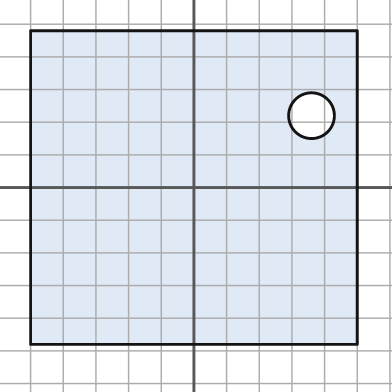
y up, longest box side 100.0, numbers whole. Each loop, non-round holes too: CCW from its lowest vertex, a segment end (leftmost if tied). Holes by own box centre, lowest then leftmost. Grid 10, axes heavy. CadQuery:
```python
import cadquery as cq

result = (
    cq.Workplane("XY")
    .moveTo(-50.0, -48.0)
    .lineTo(50.0, -48.0)
    .lineTo(50.0, 48.0)
    .lineTo(-50.0, 48.0)
    .close()
    .moveTo(36.0, 22.0)
    .circle(7.0)
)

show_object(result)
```